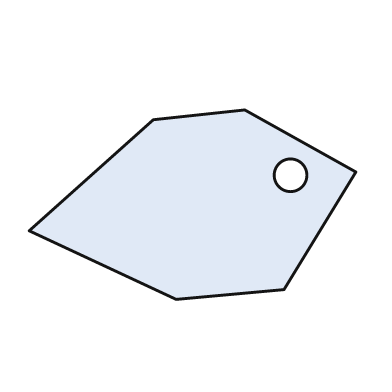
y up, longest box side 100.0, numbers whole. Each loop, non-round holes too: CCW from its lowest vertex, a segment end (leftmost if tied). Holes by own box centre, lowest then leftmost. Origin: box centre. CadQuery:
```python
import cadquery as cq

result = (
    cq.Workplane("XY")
    .moveTo(-5.0, -29.0)
    .lineTo(28.0, -26.0)
    .lineTo(50.0, 10.0)
    .lineTo(16.0, 29.0)
    .lineTo(-12.0, 26.0)
    .lineTo(-50.0, -8.0)
    .close()
    .moveTo(30.0, 9.0)
    .circle(5.0)
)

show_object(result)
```